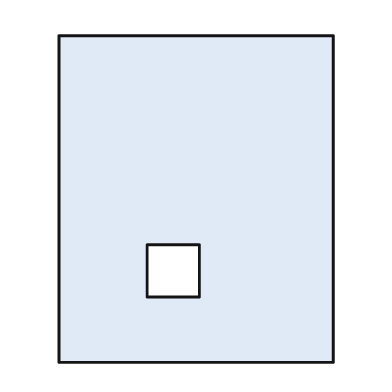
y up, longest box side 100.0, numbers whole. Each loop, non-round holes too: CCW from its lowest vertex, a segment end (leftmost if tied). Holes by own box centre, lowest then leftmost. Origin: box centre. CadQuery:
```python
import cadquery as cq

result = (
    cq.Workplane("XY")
    .moveTo(-42.0, -50.0)
    .lineTo(42.0, -50.0)
    .lineTo(42.0, 50.0)
    .lineTo(-42.0, 50.0)
    .close()
    .moveTo(-15.0, -30.0)
    .lineTo(1.0, -30.0)
    .lineTo(1.0, -14.0)
    .lineTo(-15.0, -14.0)
    .close()
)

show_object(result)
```